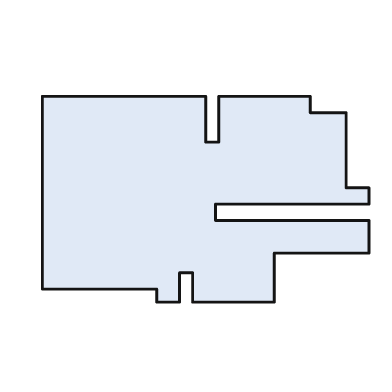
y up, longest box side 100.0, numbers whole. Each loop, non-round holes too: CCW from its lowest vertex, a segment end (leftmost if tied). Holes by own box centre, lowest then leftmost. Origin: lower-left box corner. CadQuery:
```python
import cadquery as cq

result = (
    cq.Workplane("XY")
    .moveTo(35.0, 0.0)
    .lineTo(42.0, 0.0)
    .lineTo(42.0, 9.0)
    .lineTo(46.0, 9.0)
    .lineTo(46.0, 0.0)
    .lineTo(71.0, 0.0)
    .lineTo(71.0, 15.0)
    .lineTo(100.0, 15.0)
    .lineTo(100.0, 25.0)
    .lineTo(53.0, 25.0)
    .lineTo(53.0, 30.0)
    .lineTo(100.0, 30.0)
    .lineTo(100.0, 35.0)
    .lineTo(93.0, 35.0)
    .lineTo(93.0, 58.0)
    .lineTo(82.0, 58.0)
    .lineTo(82.0, 63.0)
    .lineTo(54.0, 63.0)
    .lineTo(54.0, 49.0)
    .lineTo(50.0, 49.0)
    .lineTo(50.0, 63.0)
    .lineTo(0.0, 63.0)
    .lineTo(0.0, 4.0)
    .lineTo(35.0, 4.0)
    .close()
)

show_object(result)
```